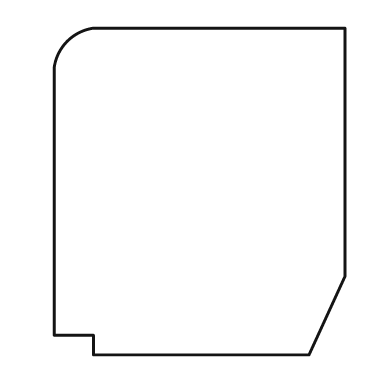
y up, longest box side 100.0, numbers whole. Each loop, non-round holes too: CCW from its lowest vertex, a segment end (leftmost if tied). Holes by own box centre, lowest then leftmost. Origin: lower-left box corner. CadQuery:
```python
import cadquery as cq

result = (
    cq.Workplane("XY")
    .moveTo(12.0, 0.0)
    .lineTo(78.0, 0.0)
    .lineTo(89.0, 24.0)
    .lineTo(89.0, 100.0)
    .lineTo(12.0, 100.0)
    .threePointArc((4.0, 96.0), (0.0, 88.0))
    .lineTo(0.0, 6.0)
    .lineTo(12.0, 6.0)
    .close()
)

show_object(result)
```